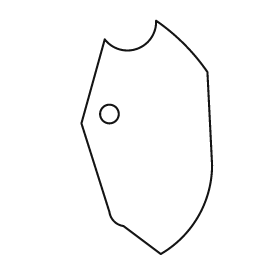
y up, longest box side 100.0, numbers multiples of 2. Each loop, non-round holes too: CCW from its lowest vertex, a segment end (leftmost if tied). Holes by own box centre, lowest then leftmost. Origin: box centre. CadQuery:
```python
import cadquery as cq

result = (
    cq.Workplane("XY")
    .moveTo(6.0, -50.0)
    .threePointArc((22.0, -34.0), (28.0, -12.0))
    .lineTo(26.0, 28.0)
    .threePointArc((16.0, 40.0), (4.0, 50.0))
    .threePointArc((-4.0, 38.0), (-18.0, 42.0))
    .lineTo(-28.0, 6.0)
    .lineTo(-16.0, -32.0)
    .threePointArc((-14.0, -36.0), (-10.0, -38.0))
    .close()
    .moveTo(-16.0, 10.0)
    .circle(4.0)
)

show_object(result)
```